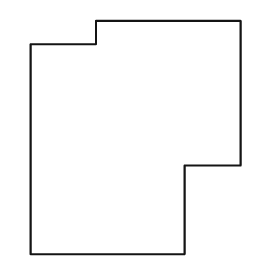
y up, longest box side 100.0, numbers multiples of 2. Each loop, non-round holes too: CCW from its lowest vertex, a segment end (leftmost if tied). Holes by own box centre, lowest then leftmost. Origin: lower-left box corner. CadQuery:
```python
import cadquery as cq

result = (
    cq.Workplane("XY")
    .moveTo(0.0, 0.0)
    .lineTo(66.0, 0.0)
    .lineTo(66.0, 38.0)
    .lineTo(90.0, 38.0)
    .lineTo(90.0, 100.0)
    .lineTo(28.0, 100.0)
    .lineTo(28.0, 90.0)
    .lineTo(0.0, 90.0)
    .close()
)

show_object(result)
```